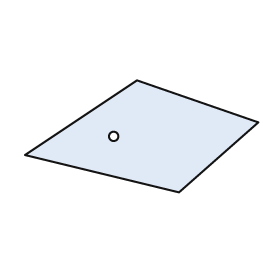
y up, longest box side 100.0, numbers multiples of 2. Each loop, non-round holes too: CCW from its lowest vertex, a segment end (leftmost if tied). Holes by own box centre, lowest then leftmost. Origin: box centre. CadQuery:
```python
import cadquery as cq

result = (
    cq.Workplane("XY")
    .moveTo(16.0, -24.0)
    .lineTo(50.0, 6.0)
    .lineTo(-2.0, 24.0)
    .lineTo(-50.0, -8.0)
    .close()
    .moveTo(-12.0, 0.0)
    .circle(2.0)
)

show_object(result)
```